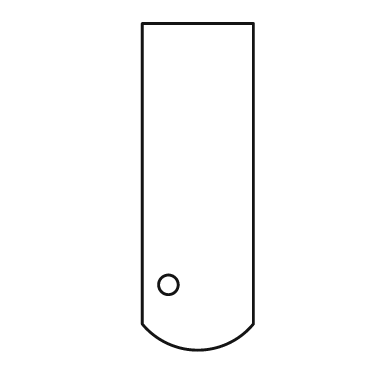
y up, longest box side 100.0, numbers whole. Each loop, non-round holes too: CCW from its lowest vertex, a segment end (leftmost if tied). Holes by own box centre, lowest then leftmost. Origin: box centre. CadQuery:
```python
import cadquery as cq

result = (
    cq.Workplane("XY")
    .moveTo(-17.0, -42.0)
    .threePointArc((0.0, -50.0), (17.0, -42.0))
    .lineTo(17.0, 50.0)
    .lineTo(-17.0, 50.0)
    .close()
    .moveTo(-9.0, -30.0)
    .circle(3.0)
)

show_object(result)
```